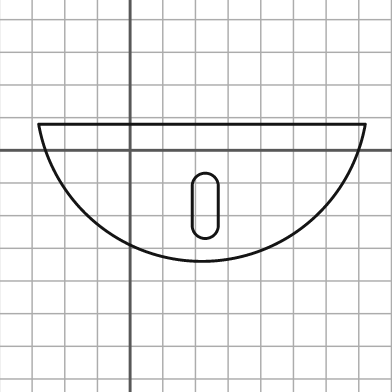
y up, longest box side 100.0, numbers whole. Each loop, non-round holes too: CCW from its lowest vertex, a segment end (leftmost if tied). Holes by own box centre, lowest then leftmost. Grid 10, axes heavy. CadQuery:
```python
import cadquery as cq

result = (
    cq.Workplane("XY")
    .moveTo(-28.0, 8.0)
    .threePointArc((22.0, -34.0), (72.0, 8.0))
    .close()
    .moveTo(19.0, -23.0)
    .threePointArc((23.0, -27.0), (27.0, -23.0))
    .lineTo(27.0, -11.0)
    .threePointArc((23.0, -7.0), (19.0, -11.0))
    .close()
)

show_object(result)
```